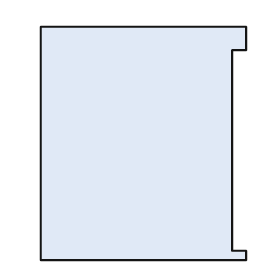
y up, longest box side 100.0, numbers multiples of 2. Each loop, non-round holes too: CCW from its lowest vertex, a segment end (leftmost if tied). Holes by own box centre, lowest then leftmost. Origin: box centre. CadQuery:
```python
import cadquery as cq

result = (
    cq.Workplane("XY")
    .moveTo(-44.0, -50.0)
    .lineTo(44.0, -50.0)
    .lineTo(44.0, -46.0)
    .lineTo(38.0, -46.0)
    .lineTo(38.0, 40.0)
    .lineTo(44.0, 40.0)
    .lineTo(44.0, 50.0)
    .lineTo(-44.0, 50.0)
    .close()
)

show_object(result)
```